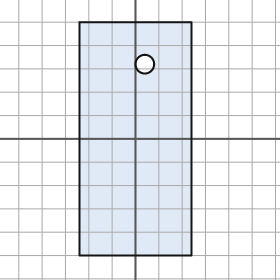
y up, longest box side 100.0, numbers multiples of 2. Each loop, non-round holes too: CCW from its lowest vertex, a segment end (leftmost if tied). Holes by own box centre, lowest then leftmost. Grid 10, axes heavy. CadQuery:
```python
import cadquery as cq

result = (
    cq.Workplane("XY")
    .moveTo(-24.0, -50.0)
    .lineTo(24.0, -50.0)
    .lineTo(24.0, 50.0)
    .lineTo(-24.0, 50.0)
    .close()
    .moveTo(4.0, 32.0)
    .circle(4.0)
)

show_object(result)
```